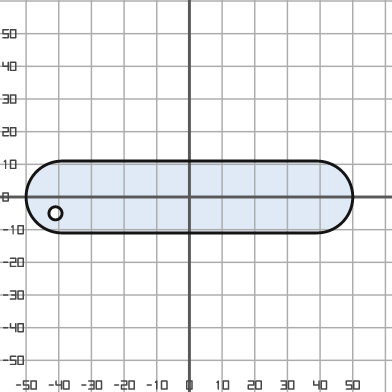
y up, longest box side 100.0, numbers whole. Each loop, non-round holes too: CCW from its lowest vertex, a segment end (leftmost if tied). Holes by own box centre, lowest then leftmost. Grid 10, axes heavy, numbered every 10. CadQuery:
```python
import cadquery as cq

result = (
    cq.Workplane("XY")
    .moveTo(-39.0, -11.0)
    .lineTo(39.0, -11.0)
    .threePointArc((50.0, 0.0), (39.0, 11.0))
    .lineTo(-39.0, 11.0)
    .threePointArc((-50.0, 0.0), (-39.0, -11.0))
    .close()
    .moveTo(-41.0, -5.0)
    .circle(2.0)
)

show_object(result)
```